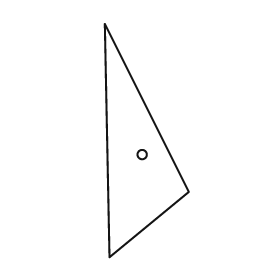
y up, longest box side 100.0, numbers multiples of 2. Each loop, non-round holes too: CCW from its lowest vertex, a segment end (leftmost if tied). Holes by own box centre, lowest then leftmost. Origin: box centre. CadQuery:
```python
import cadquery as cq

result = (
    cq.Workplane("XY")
    .moveTo(-16.0, -50.0)
    .lineTo(18.0, -22.0)
    .lineTo(-18.0, 50.0)
    .close()
    .moveTo(-2.0, -6.0)
    .circle(2.0)
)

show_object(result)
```